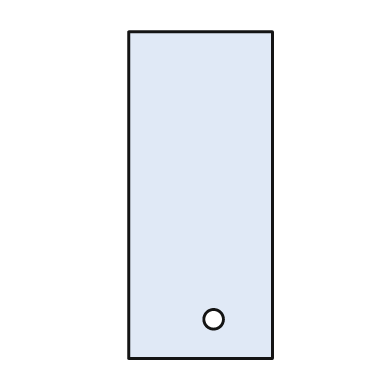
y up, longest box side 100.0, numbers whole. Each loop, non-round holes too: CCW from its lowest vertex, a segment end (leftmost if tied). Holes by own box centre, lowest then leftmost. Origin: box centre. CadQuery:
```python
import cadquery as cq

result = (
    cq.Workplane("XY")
    .moveTo(-22.0, -50.0)
    .lineTo(22.0, -50.0)
    .lineTo(22.0, 50.0)
    .lineTo(-22.0, 50.0)
    .close()
    .moveTo(4.0, -38.0)
    .circle(3.0)
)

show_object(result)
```